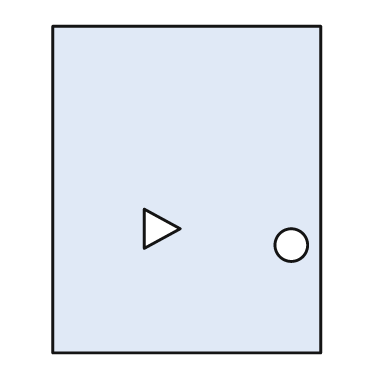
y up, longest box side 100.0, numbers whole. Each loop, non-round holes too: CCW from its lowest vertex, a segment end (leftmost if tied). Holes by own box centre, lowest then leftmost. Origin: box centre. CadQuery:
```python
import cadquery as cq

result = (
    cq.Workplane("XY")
    .moveTo(-41.0, -50.0)
    .lineTo(41.0, -50.0)
    .lineTo(41.0, 50.0)
    .lineTo(-41.0, 50.0)
    .close()
    .moveTo(32.0, -17.0)
    .circle(5.0)
    .moveTo(-13.0, -18.0)
    .lineTo(-2.0, -12.0)
    .lineTo(-13.0, -6.0)
    .close()
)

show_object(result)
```